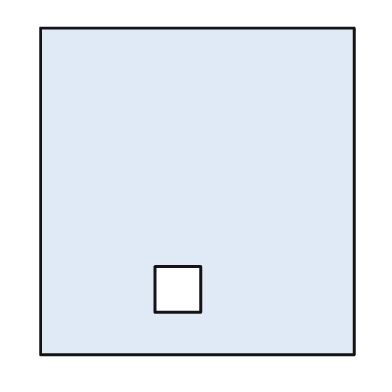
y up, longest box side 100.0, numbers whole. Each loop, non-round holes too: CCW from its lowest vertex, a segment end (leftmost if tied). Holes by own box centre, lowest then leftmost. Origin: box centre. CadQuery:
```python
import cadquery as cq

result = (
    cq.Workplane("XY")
    .moveTo(-48.0, -50.0)
    .lineTo(48.0, -50.0)
    .lineTo(48.0, 50.0)
    .lineTo(-48.0, 50.0)
    .close()
    .moveTo(-13.0, -37.0)
    .lineTo(1.0, -37.0)
    .lineTo(1.0, -23.0)
    .lineTo(-13.0, -23.0)
    .close()
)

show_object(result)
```